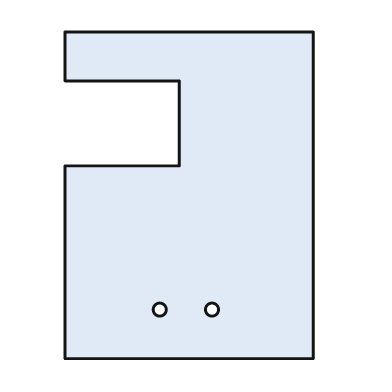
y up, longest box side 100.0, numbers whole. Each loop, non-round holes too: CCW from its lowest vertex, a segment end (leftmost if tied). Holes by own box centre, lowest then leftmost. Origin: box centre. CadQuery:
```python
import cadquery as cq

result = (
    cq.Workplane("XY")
    .moveTo(-38.0, -50.0)
    .lineTo(38.0, -50.0)
    .lineTo(38.0, 50.0)
    .lineTo(-38.0, 50.0)
    .lineTo(-38.0, 35.0)
    .lineTo(-3.0, 35.0)
    .lineTo(-3.0, 9.0)
    .lineTo(-38.0, 9.0)
    .close()
    .moveTo(-9.0, -35.0)
    .circle(2.0)
    .moveTo(7.0, -35.0)
    .circle(2.0)
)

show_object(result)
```